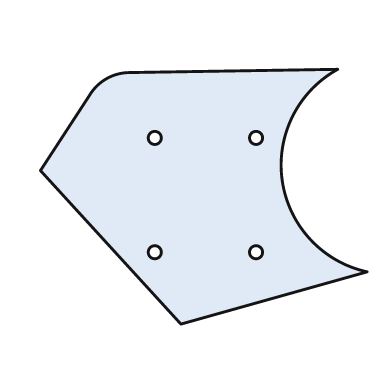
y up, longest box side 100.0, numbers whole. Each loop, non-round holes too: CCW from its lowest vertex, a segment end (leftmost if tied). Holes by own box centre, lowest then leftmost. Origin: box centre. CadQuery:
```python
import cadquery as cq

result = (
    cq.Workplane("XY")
    .moveTo(-7.0, -39.0)
    .lineTo(50.0, -23.0)
    .threePointArc((24.0, 5.0), (41.0, 39.0))
    .lineTo(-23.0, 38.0)
    .threePointArc((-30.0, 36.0), (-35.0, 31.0))
    .lineTo(-50.0, 8.0)
    .close()
    .moveTo(-15.0, -17.0)
    .circle(2.0)
    .moveTo(16.0, -17.0)
    .circle(2.0)
    .moveTo(-15.0, 18.0)
    .circle(2.0)
    .moveTo(16.0, 18.0)
    .circle(2.0)
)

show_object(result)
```